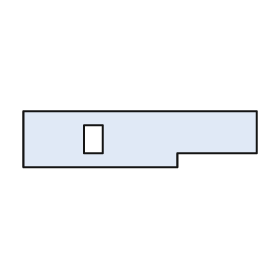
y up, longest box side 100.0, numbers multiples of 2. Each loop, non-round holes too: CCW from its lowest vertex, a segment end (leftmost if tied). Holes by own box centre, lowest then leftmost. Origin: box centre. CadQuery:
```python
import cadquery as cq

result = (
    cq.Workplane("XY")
    .moveTo(-50.0, -12.0)
    .lineTo(16.0, -12.0)
    .lineTo(16.0, -6.0)
    .lineTo(50.0, -6.0)
    .lineTo(50.0, 12.0)
    .lineTo(-50.0, 12.0)
    .close()
    .moveTo(-24.0, -6.0)
    .lineTo(-16.0, -6.0)
    .lineTo(-16.0, 6.0)
    .lineTo(-24.0, 6.0)
    .close()
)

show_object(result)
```